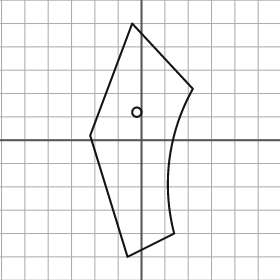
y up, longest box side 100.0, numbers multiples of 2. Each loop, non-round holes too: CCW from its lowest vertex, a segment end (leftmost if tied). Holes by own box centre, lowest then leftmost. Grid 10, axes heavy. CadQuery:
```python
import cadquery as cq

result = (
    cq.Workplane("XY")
    .moveTo(-6.0, -50.0)
    .lineTo(14.0, -40.0)
    .threePointArc((12.0, -8.0), (22.0, 22.0))
    .lineTo(-4.0, 50.0)
    .lineTo(-22.0, 2.0)
    .close()
    .moveTo(-2.0, 12.0)
    .circle(2.0)
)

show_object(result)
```